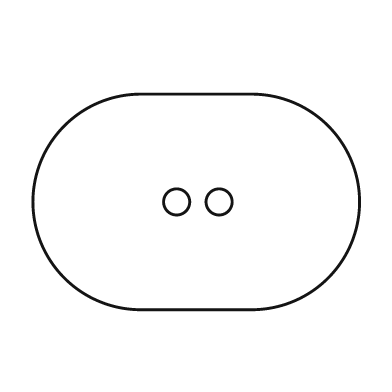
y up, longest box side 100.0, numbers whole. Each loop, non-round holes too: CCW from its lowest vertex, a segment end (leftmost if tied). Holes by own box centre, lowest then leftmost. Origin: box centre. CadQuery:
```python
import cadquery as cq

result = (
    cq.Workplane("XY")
    .moveTo(-17.0, -33.0)
    .lineTo(17.0, -33.0)
    .threePointArc((50.0, 0.0), (17.0, 33.0))
    .lineTo(-17.0, 33.0)
    .threePointArc((-50.0, 0.0), (-17.0, -33.0))
    .close()
    .moveTo(-6.0, 0.0)
    .circle(4.0)
    .moveTo(7.0, 0.0)
    .circle(4.0)
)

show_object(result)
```